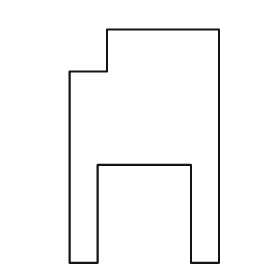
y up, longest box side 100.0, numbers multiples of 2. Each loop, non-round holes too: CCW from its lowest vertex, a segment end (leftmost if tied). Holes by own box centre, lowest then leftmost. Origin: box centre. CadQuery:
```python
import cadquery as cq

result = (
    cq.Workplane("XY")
    .moveTo(-32.0, -50.0)
    .lineTo(-20.0, -50.0)
    .lineTo(-20.0, -8.0)
    .lineTo(20.0, -8.0)
    .lineTo(20.0, -50.0)
    .lineTo(32.0, -50.0)
    .lineTo(32.0, 50.0)
    .lineTo(-16.0, 50.0)
    .lineTo(-16.0, 32.0)
    .lineTo(-32.0, 32.0)
    .close()
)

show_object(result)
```